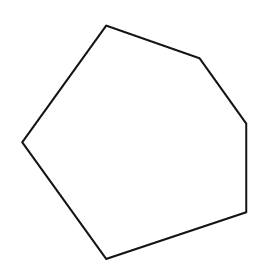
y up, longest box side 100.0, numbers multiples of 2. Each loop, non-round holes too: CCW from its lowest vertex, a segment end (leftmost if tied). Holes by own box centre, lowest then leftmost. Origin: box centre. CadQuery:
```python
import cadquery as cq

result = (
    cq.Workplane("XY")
    .moveTo(-12.0, -50.0)
    .lineTo(48.0, -30.0)
    .lineTo(48.0, 8.0)
    .lineTo(28.0, 36.0)
    .lineTo(-12.0, 50.0)
    .lineTo(-48.0, 0.0)
    .close()
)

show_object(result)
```